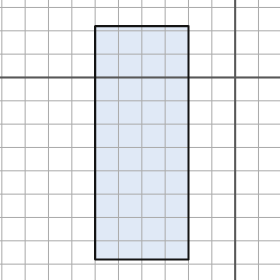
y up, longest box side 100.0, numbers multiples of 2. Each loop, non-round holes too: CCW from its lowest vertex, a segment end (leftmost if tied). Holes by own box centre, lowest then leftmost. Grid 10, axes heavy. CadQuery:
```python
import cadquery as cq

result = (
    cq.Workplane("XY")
    .moveTo(-60.0, -78.0)
    .lineTo(-20.0, -78.0)
    .lineTo(-20.0, 22.0)
    .lineTo(-60.0, 22.0)
    .close()
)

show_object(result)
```